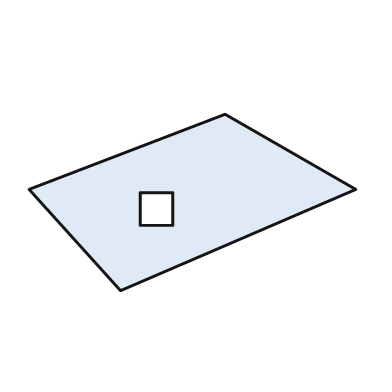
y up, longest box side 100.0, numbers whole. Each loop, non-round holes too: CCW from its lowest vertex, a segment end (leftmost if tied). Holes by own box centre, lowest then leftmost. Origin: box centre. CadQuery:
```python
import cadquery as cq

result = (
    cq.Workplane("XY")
    .moveTo(-22.0, -27.0)
    .lineTo(50.0, 4.0)
    .lineTo(10.0, 27.0)
    .lineTo(-50.0, 4.0)
    .close()
    .moveTo(-16.0, -7.0)
    .lineTo(-6.0, -7.0)
    .lineTo(-6.0, 3.0)
    .lineTo(-16.0, 3.0)
    .close()
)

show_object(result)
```